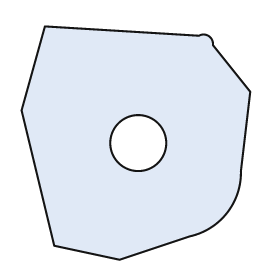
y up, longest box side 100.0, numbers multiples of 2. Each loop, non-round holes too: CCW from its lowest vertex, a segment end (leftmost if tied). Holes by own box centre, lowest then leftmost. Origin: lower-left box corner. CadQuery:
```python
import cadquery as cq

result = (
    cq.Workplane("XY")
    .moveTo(42.0, 0.0)
    .lineTo(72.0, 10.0)
    .threePointArc((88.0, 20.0), (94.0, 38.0))
    .lineTo(98.0, 72.0)
    .lineTo(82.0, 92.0)
    .threePointArc((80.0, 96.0), (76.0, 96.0))
    .lineTo(10.0, 100.0)
    .lineTo(0.0, 64.0)
    .lineTo(14.0, 6.0)
    .close()
    .moveTo(50.0, 50.0)
    .circle(12.0)
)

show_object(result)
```